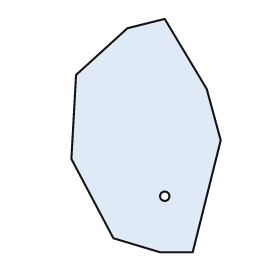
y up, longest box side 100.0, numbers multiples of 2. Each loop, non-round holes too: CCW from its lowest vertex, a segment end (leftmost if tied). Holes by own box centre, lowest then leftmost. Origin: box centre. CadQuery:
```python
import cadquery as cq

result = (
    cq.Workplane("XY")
    .moveTo(6.0, -50.0)
    .lineTo(20.0, -50.0)
    .lineTo(32.0, -2.0)
    .lineTo(26.0, 20.0)
    .lineTo(8.0, 50.0)
    .lineTo(-8.0, 46.0)
    .lineTo(-30.0, 26.0)
    .lineTo(-32.0, -10.0)
    .lineTo(-14.0, -44.0)
    .close()
    .moveTo(8.0, -26.0)
    .circle(2.0)
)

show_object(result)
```